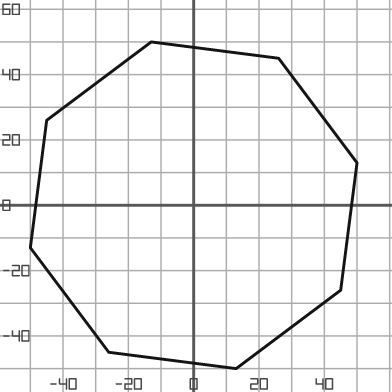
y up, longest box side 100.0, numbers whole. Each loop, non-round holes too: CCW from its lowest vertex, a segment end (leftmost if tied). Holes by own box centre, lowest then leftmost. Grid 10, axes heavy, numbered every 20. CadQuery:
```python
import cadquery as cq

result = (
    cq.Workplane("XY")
    .moveTo(13.0, -50.0)
    .lineTo(45.0, -26.0)
    .lineTo(50.0, 13.0)
    .lineTo(26.0, 45.0)
    .lineTo(-13.0, 50.0)
    .lineTo(-45.0, 26.0)
    .lineTo(-50.0, -13.0)
    .lineTo(-26.0, -45.0)
    .close()
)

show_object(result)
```